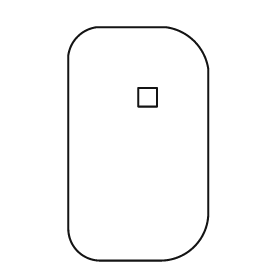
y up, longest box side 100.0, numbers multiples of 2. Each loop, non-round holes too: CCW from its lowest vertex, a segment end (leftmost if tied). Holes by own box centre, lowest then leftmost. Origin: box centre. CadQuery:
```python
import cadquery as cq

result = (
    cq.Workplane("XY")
    .moveTo(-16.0, -50.0)
    .lineTo(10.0, -50.0)
    .threePointArc((24.0, -44.0), (30.0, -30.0))
    .lineTo(30.0, 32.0)
    .threePointArc((24.0, 44.0), (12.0, 50.0))
    .lineTo(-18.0, 50.0)
    .threePointArc((-26.0, 46.0), (-30.0, 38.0))
    .lineTo(-30.0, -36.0)
    .threePointArc((-26.0, -46.0), (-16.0, -50.0))
    .close()
    .moveTo(0.0, 16.0)
    .lineTo(8.0, 16.0)
    .lineTo(8.0, 24.0)
    .lineTo(0.0, 24.0)
    .close()
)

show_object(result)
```